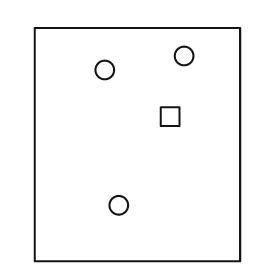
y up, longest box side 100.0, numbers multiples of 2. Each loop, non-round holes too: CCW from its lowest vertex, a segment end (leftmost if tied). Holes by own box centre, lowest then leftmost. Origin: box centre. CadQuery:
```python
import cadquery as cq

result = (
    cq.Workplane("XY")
    .moveTo(-44.0, -50.0)
    .lineTo(44.0, -50.0)
    .lineTo(44.0, 50.0)
    .lineTo(-44.0, 50.0)
    .close()
    .moveTo(-8.0, -26.0)
    .circle(4.0)
    .moveTo(10.0, 8.0)
    .lineTo(18.0, 8.0)
    .lineTo(18.0, 16.0)
    .lineTo(10.0, 16.0)
    .close()
    .moveTo(-14.0, 32.0)
    .circle(4.0)
    .moveTo(20.0, 38.0)
    .circle(4.0)
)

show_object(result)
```